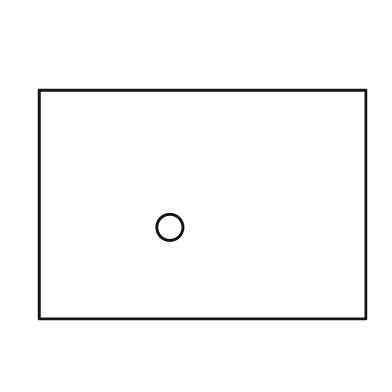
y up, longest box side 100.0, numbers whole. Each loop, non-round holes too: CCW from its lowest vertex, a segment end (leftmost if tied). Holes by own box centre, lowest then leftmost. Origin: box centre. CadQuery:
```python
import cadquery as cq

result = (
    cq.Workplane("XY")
    .moveTo(-50.0, -35.0)
    .lineTo(50.0, -35.0)
    .lineTo(50.0, 35.0)
    .lineTo(-50.0, 35.0)
    .close()
    .moveTo(-10.0, -7.0)
    .circle(4.0)
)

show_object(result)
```